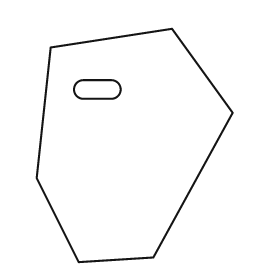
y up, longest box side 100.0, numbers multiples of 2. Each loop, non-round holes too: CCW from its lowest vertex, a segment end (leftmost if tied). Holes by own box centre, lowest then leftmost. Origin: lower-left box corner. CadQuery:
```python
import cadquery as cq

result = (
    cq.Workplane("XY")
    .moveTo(18.0, 0.0)
    .lineTo(50.0, 2.0)
    .lineTo(84.0, 64.0)
    .lineTo(58.0, 100.0)
    .lineTo(6.0, 92.0)
    .lineTo(0.0, 36.0)
    .close()
    .moveTo(20.0, 70.0)
    .lineTo(32.0, 70.0)
    .threePointArc((36.0, 74.0), (32.0, 78.0))
    .lineTo(20.0, 78.0)
    .threePointArc((16.0, 74.0), (20.0, 70.0))
    .close()
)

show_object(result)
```